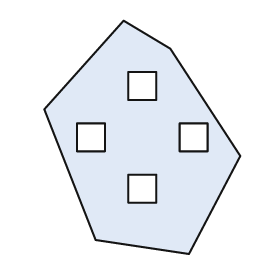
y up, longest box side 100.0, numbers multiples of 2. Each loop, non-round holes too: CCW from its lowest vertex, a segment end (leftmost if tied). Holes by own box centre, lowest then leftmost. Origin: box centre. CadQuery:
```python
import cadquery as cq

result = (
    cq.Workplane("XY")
    .moveTo(20.0, -50.0)
    .lineTo(42.0, -8.0)
    .lineTo(12.0, 38.0)
    .lineTo(-8.0, 50.0)
    .lineTo(-42.0, 12.0)
    .lineTo(-20.0, -44.0)
    .close()
    .moveTo(-6.0, -28.0)
    .lineTo(6.0, -28.0)
    .lineTo(6.0, -16.0)
    .lineTo(-6.0, -16.0)
    .close()
    .moveTo(-28.0, -6.0)
    .lineTo(-16.0, -6.0)
    .lineTo(-16.0, 6.0)
    .lineTo(-28.0, 6.0)
    .close()
    .moveTo(16.0, -6.0)
    .lineTo(28.0, -6.0)
    .lineTo(28.0, 6.0)
    .lineTo(16.0, 6.0)
    .close()
    .moveTo(-6.0, 16.0)
    .lineTo(6.0, 16.0)
    .lineTo(6.0, 28.0)
    .lineTo(-6.0, 28.0)
    .close()
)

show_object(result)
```